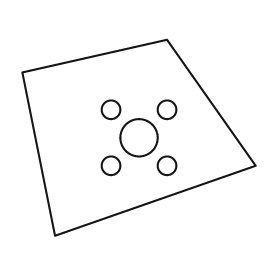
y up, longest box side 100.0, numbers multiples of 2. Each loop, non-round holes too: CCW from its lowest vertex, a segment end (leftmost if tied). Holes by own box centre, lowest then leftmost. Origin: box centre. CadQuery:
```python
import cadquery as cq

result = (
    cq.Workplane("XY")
    .moveTo(-36.0, -42.0)
    .lineTo(50.0, -12.0)
    .lineTo(12.0, 42.0)
    .lineTo(-50.0, 28.0)
    .close()
    .moveTo(-12.0, -12.0)
    .circle(4.0)
    .moveTo(12.0, -12.0)
    .circle(4.0)
    .moveTo(0.0, 0.0)
    .circle(8.0)
    .moveTo(-12.0, 12.0)
    .circle(4.0)
    .moveTo(12.0, 12.0)
    .circle(4.0)
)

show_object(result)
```